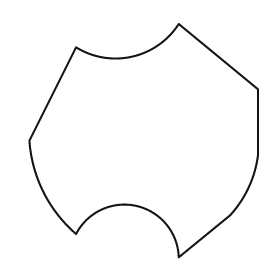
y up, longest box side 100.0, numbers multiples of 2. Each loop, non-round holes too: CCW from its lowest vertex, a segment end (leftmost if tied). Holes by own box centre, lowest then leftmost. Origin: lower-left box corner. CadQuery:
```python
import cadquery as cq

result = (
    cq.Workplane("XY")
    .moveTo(64.0, 0.0)
    .lineTo(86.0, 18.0)
    .threePointArc((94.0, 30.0), (98.0, 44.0))
    .lineTo(98.0, 72.0)
    .lineTo(64.0, 100.0)
    .threePointArc((44.0, 86.0), (20.0, 90.0))
    .lineTo(0.0, 50.0)
    .threePointArc((6.0, 28.0), (20.0, 10.0))
    .threePointArc((46.0, 22.0), (64.0, 0.0))
    .close()
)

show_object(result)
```